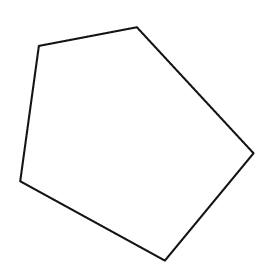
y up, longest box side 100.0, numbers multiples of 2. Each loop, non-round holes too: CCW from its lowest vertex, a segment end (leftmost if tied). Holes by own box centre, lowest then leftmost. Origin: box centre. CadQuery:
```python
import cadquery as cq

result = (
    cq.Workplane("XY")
    .moveTo(12.0, -50.0)
    .lineTo(50.0, -4.0)
    .lineTo(0.0, 50.0)
    .lineTo(-42.0, 42.0)
    .lineTo(-50.0, -16.0)
    .close()
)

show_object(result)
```